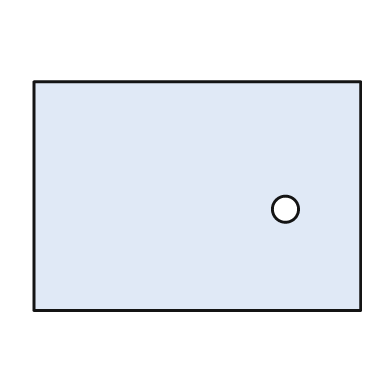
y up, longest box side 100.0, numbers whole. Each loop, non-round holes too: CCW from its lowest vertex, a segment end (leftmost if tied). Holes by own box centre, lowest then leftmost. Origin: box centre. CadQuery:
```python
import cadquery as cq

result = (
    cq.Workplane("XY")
    .moveTo(-50.0, -35.0)
    .lineTo(50.0, -35.0)
    .lineTo(50.0, 35.0)
    .lineTo(-50.0, 35.0)
    .close()
    .moveTo(27.0, -4.0)
    .circle(4.0)
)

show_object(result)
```